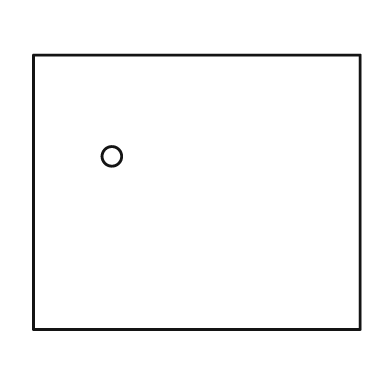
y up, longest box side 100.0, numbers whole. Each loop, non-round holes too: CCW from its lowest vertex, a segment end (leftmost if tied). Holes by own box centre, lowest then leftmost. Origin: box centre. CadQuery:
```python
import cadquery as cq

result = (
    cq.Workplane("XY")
    .moveTo(-50.0, -42.0)
    .lineTo(50.0, -42.0)
    .lineTo(50.0, 42.0)
    .lineTo(-50.0, 42.0)
    .close()
    .moveTo(-26.0, 11.0)
    .circle(3.0)
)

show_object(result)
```